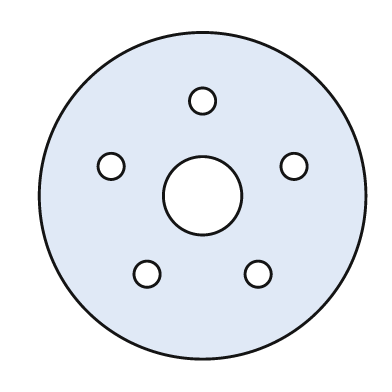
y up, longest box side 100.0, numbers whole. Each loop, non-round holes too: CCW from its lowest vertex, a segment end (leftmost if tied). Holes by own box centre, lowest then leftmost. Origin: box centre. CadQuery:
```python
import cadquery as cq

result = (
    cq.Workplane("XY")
    .moveTo(0.0, 0.0)
    .circle(50.0)
    .moveTo(-17.0, -24.0)
    .circle(4.0)
    .moveTo(17.0, -24.0)
    .circle(4.0)
    .moveTo(0.0, 0.0)
    .circle(12.0)
    .moveTo(-28.0, 9.0)
    .circle(4.0)
    .moveTo(28.0, 9.0)
    .circle(4.0)
    .moveTo(0.0, 29.0)
    .circle(4.0)
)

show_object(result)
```